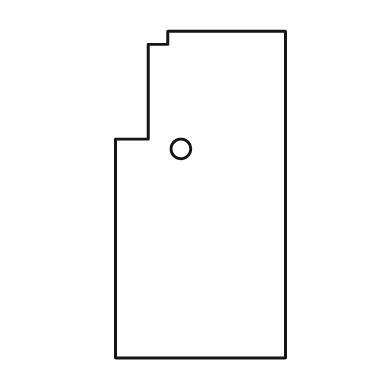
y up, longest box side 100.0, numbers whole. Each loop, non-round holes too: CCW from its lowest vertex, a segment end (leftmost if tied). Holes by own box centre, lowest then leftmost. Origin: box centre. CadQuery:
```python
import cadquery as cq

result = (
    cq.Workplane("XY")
    .moveTo(-26.0, -50.0)
    .lineTo(26.0, -50.0)
    .lineTo(26.0, 50.0)
    .lineTo(-10.0, 50.0)
    .lineTo(-10.0, 46.0)
    .lineTo(-16.0, 46.0)
    .lineTo(-16.0, 17.0)
    .lineTo(-26.0, 17.0)
    .close()
    .moveTo(-6.0, 14.0)
    .circle(3.0)
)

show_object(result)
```